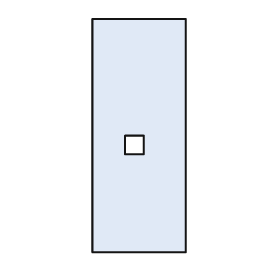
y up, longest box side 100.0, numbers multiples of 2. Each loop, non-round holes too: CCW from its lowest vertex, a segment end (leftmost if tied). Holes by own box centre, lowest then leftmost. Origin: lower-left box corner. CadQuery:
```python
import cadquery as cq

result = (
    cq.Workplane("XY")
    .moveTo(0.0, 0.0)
    .lineTo(40.0, 0.0)
    .lineTo(40.0, 100.0)
    .lineTo(0.0, 100.0)
    .close()
    .moveTo(14.0, 42.0)
    .lineTo(22.0, 42.0)
    .lineTo(22.0, 50.0)
    .lineTo(14.0, 50.0)
    .close()
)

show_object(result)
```